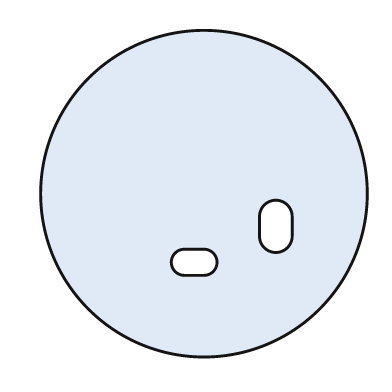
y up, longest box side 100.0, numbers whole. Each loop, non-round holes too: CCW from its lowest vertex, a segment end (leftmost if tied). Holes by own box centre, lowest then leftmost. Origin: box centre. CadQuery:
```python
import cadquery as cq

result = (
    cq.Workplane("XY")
    .moveTo(0.0, 0.0)
    .circle(50.0)
    .moveTo(-6.0, -25.0)
    .lineTo(0.0, -25.0)
    .threePointArc((4.0, -21.0), (0.0, -17.0))
    .lineTo(-6.0, -17.0)
    .threePointArc((-10.0, -21.0), (-6.0, -25.0))
    .close()
    .moveTo(17.0, -13.0)
    .threePointArc((22.0, -18.0), (27.0, -13.0))
    .lineTo(27.0, -7.0)
    .threePointArc((22.0, -2.0), (17.0, -7.0))
    .close()
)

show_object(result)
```